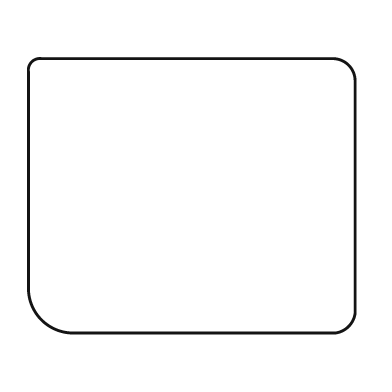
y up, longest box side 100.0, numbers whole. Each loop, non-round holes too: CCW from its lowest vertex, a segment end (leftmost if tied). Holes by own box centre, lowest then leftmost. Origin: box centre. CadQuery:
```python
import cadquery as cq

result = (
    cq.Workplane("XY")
    .moveTo(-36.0, -42.0)
    .lineTo(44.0, -42.0)
    .threePointArc((48.0, -40.0), (50.0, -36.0))
    .lineTo(50.0, 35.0)
    .threePointArc((48.0, 40.0), (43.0, 42.0))
    .lineTo(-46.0, 42.0)
    .threePointArc((-49.0, 41.0), (-50.0, 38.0))
    .lineTo(-50.0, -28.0)
    .threePointArc((-46.0, -38.0), (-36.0, -42.0))
    .close()
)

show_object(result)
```